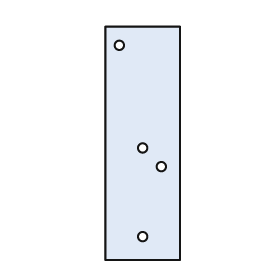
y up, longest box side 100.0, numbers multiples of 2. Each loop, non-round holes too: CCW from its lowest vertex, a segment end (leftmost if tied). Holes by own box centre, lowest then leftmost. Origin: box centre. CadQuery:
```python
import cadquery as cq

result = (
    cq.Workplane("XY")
    .moveTo(-16.0, -50.0)
    .lineTo(16.0, -50.0)
    .lineTo(16.0, 50.0)
    .lineTo(-16.0, 50.0)
    .close()
    .moveTo(0.0, -40.0)
    .circle(2.0)
    .moveTo(8.0, -10.0)
    .circle(2.0)
    .moveTo(0.0, -2.0)
    .circle(2.0)
    .moveTo(-10.0, 42.0)
    .circle(2.0)
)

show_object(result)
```